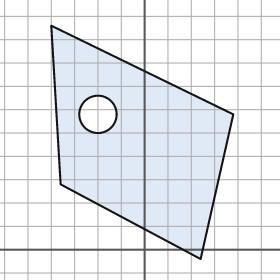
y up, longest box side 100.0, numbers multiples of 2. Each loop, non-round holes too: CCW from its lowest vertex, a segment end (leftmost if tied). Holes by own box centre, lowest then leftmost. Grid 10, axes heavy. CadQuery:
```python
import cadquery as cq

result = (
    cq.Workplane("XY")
    .moveTo(24.0, -4.0)
    .lineTo(38.0, 58.0)
    .lineTo(-40.0, 96.0)
    .lineTo(-36.0, 28.0)
    .close()
    .moveTo(-20.0, 58.0)
    .circle(8.0)
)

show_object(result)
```